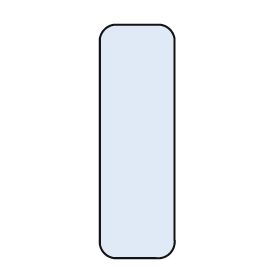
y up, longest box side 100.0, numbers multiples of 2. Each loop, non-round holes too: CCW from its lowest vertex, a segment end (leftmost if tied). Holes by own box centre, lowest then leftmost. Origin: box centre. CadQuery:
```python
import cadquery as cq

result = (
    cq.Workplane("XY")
    .moveTo(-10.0, -50.0)
    .lineTo(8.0, -50.0)
    .threePointArc((14.0, -48.0), (16.0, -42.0))
    .lineTo(16.0, 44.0)
    .threePointArc((14.0, 48.0), (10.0, 50.0))
    .lineTo(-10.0, 50.0)
    .threePointArc((-14.0, 48.0), (-16.0, 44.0))
    .lineTo(-16.0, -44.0)
    .threePointArc((-14.0, -48.0), (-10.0, -50.0))
    .close()
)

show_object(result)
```